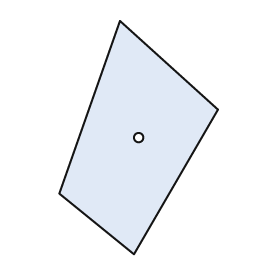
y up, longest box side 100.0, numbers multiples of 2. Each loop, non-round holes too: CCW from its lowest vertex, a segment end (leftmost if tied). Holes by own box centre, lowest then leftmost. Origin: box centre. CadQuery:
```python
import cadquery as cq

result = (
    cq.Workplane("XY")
    .moveTo(-2.0, -50.0)
    .lineTo(34.0, 12.0)
    .lineTo(-8.0, 50.0)
    .lineTo(-34.0, -24.0)
    .close()
    .moveTo(0.0, 0.0)
    .circle(2.0)
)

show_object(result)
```